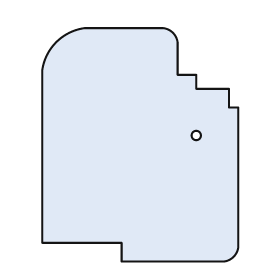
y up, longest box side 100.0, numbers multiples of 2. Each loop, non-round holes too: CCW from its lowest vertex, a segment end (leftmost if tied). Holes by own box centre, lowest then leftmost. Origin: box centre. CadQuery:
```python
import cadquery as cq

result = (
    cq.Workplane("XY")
    .moveTo(-8.0, -50.0)
    .lineTo(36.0, -50.0)
    .threePointArc((40.0, -48.0), (42.0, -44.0))
    .lineTo(42.0, 16.0)
    .lineTo(38.0, 16.0)
    .lineTo(38.0, 24.0)
    .lineTo(24.0, 24.0)
    .lineTo(24.0, 30.0)
    .lineTo(16.0, 30.0)
    .lineTo(16.0, 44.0)
    .threePointArc((14.0, 48.0), (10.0, 50.0))
    .lineTo(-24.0, 50.0)
    .threePointArc((-36.0, 44.0), (-42.0, 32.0))
    .lineTo(-42.0, -42.0)
    .lineTo(-8.0, -42.0)
    .close()
    .moveTo(24.0, 4.0)
    .circle(2.0)
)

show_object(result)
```